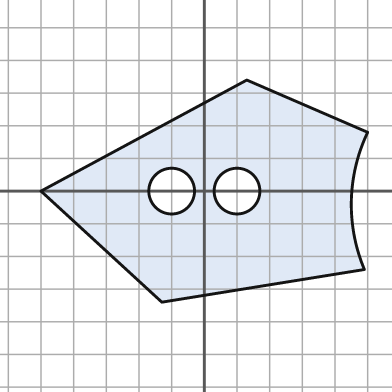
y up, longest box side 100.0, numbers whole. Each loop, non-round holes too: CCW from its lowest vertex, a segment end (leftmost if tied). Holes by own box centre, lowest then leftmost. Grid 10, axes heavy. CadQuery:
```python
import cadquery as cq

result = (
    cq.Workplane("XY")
    .moveTo(-13.0, -34.0)
    .lineTo(49.0, -24.0)
    .threePointArc((45.0, -3.0), (50.0, 18.0))
    .lineTo(13.0, 34.0)
    .lineTo(-50.0, 0.0)
    .close()
    .moveTo(-10.0, 0.0)
    .circle(7.0)
    .moveTo(10.0, 0.0)
    .circle(7.0)
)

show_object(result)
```